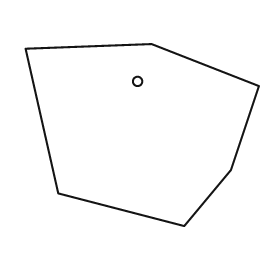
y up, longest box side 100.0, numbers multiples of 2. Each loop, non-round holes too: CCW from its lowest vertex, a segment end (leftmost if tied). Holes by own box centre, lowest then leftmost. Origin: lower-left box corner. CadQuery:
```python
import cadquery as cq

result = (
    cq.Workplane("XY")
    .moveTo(68.0, 0.0)
    .lineTo(88.0, 24.0)
    .lineTo(100.0, 60.0)
    .lineTo(54.0, 78.0)
    .lineTo(0.0, 76.0)
    .lineTo(14.0, 14.0)
    .close()
    .moveTo(48.0, 62.0)
    .circle(2.0)
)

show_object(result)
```